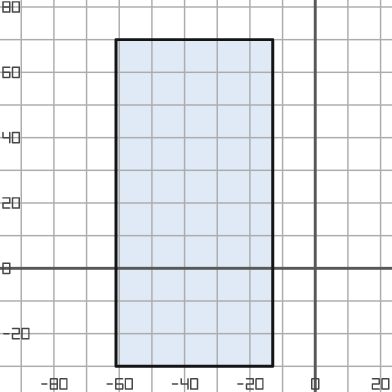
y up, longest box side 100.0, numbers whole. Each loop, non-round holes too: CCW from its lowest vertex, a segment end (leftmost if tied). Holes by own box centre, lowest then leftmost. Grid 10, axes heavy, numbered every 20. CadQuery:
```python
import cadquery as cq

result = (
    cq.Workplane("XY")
    .moveTo(-61.0, -30.0)
    .lineTo(-13.0, -30.0)
    .lineTo(-13.0, 70.0)
    .lineTo(-61.0, 70.0)
    .close()
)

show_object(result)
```